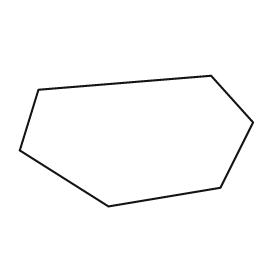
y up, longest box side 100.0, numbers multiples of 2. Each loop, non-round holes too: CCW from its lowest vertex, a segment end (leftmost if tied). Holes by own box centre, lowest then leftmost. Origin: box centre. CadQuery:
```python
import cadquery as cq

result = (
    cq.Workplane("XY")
    .moveTo(-12.0, -28.0)
    .lineTo(36.0, -20.0)
    .lineTo(50.0, 8.0)
    .lineTo(32.0, 28.0)
    .lineTo(-42.0, 22.0)
    .lineTo(-50.0, -4.0)
    .close()
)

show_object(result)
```